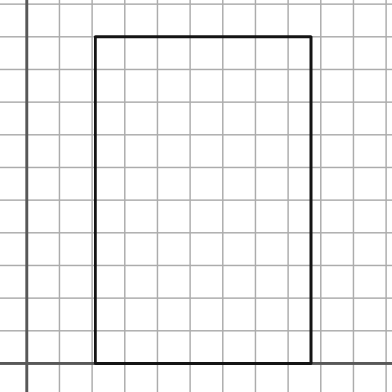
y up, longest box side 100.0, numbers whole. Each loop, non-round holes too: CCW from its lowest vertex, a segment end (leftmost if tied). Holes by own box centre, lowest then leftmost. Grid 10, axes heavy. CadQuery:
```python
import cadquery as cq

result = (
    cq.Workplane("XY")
    .moveTo(21.0, 0.0)
    .lineTo(87.0, 0.0)
    .lineTo(87.0, 100.0)
    .lineTo(21.0, 100.0)
    .close()
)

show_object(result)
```